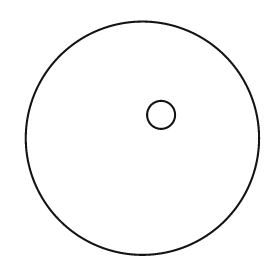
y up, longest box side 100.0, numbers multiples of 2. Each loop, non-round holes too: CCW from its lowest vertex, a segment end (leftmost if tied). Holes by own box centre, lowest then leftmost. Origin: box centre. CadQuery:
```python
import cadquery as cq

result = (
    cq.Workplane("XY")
    .moveTo(0.0, 0.0)
    .circle(50.0)
    .moveTo(8.0, 10.0)
    .circle(6.0)
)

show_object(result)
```